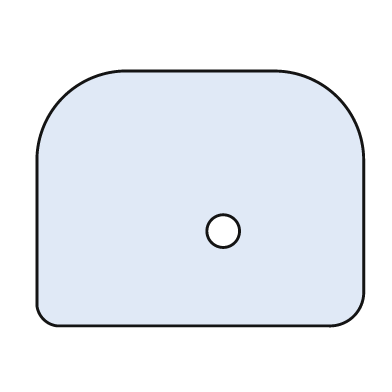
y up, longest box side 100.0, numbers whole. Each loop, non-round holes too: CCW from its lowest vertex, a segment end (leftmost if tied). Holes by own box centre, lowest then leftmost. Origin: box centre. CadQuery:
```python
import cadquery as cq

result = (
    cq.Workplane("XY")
    .moveTo(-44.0, -39.0)
    .lineTo(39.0, -39.0)
    .threePointArc((47.0, -36.0), (50.0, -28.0))
    .lineTo(50.0, 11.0)
    .threePointArc((42.0, 31.0), (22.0, 39.0))
    .lineTo(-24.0, 39.0)
    .threePointArc((-42.0, 31.0), (-50.0, 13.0))
    .lineTo(-50.0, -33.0)
    .threePointArc((-48.0, -37.0), (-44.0, -39.0))
    .close()
    .moveTo(7.0, -10.0)
    .circle(5.0)
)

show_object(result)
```